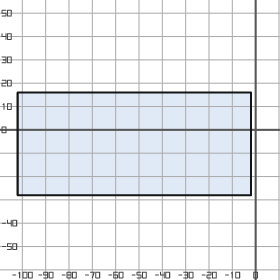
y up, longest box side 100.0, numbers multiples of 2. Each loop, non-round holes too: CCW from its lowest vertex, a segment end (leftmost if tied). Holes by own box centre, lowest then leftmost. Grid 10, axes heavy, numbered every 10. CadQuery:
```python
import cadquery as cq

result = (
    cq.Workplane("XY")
    .moveTo(-102.0, -28.0)
    .lineTo(-2.0, -28.0)
    .lineTo(-2.0, 16.0)
    .lineTo(-102.0, 16.0)
    .close()
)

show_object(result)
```